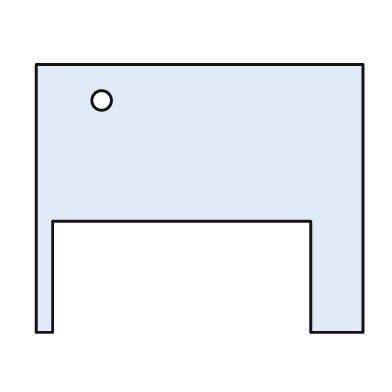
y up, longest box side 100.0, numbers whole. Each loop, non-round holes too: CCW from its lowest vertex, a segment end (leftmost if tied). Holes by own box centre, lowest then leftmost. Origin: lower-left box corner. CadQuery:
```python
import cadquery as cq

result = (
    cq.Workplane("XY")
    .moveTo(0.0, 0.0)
    .lineTo(5.0, 0.0)
    .lineTo(5.0, 34.0)
    .lineTo(84.0, 34.0)
    .lineTo(84.0, 0.0)
    .lineTo(100.0, 0.0)
    .lineTo(100.0, 82.0)
    .lineTo(0.0, 82.0)
    .close()
    .moveTo(20.0, 71.0)
    .circle(3.0)
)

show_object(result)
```